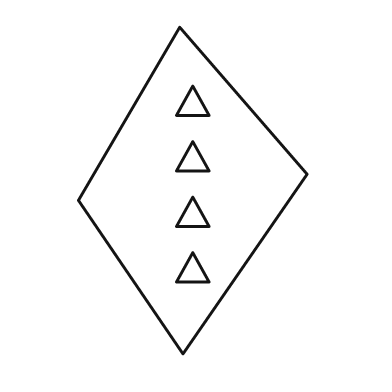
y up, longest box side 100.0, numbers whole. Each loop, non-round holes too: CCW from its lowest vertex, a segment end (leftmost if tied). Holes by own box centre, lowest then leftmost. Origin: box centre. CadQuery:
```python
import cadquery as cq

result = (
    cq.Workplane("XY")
    .moveTo(-3.0, -50.0)
    .lineTo(35.0, 5.0)
    .lineTo(-4.0, 50.0)
    .lineTo(-35.0, -3.0)
    .close()
    .moveTo(-5.0, -28.0)
    .lineTo(5.0, -28.0)
    .lineTo(0.0, -19.0)
    .close()
    .moveTo(-5.0, -11.0)
    .lineTo(5.0, -11.0)
    .lineTo(0.0, -2.0)
    .close()
    .moveTo(-5.0, 6.0)
    .lineTo(5.0, 6.0)
    .lineTo(0.0, 15.0)
    .close()
    .moveTo(-5.0, 23.0)
    .lineTo(5.0, 23.0)
    .lineTo(0.0, 32.0)
    .close()
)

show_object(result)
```